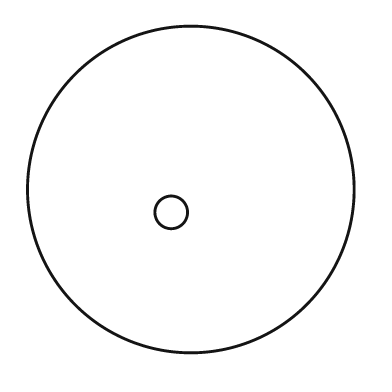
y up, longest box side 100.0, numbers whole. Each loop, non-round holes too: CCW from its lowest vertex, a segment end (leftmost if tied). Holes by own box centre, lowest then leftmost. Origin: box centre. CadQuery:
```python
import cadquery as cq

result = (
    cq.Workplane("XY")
    .moveTo(0.0, 0.0)
    .circle(50.0)
    .moveTo(-6.0, -7.0)
    .circle(5.0)
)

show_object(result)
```